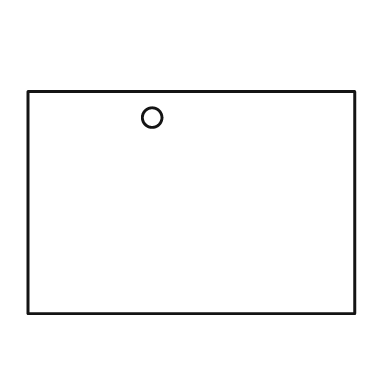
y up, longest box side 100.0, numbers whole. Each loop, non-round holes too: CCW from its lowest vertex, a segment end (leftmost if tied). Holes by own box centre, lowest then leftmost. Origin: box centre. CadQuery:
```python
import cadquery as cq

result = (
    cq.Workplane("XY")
    .moveTo(-50.0, -34.0)
    .lineTo(50.0, -34.0)
    .lineTo(50.0, 34.0)
    .lineTo(-50.0, 34.0)
    .close()
    .moveTo(-12.0, 26.0)
    .circle(3.0)
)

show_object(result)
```